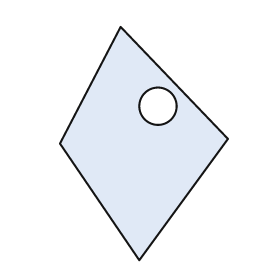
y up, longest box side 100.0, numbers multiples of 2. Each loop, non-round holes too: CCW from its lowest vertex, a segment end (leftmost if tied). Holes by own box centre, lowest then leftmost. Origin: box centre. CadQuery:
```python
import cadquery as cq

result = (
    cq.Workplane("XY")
    .moveTo(-2.0, -50.0)
    .lineTo(36.0, 2.0)
    .lineTo(-10.0, 50.0)
    .lineTo(-36.0, 0.0)
    .close()
    .moveTo(6.0, 16.0)
    .circle(8.0)
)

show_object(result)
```